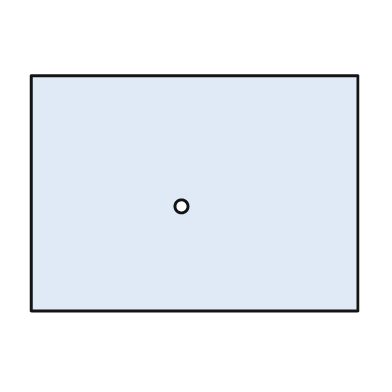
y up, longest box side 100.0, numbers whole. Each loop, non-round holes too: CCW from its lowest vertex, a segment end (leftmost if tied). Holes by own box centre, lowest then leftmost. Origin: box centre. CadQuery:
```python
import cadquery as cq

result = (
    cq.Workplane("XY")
    .moveTo(-50.0, -36.0)
    .lineTo(50.0, -36.0)
    .lineTo(50.0, 36.0)
    .lineTo(-50.0, 36.0)
    .close()
    .moveTo(-4.0, -4.0)
    .circle(2.0)
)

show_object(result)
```